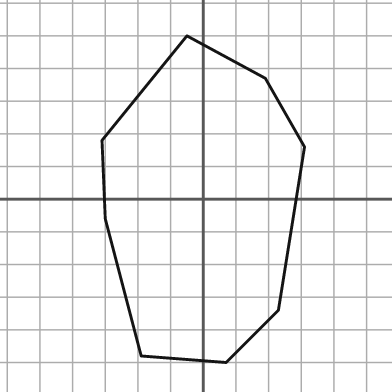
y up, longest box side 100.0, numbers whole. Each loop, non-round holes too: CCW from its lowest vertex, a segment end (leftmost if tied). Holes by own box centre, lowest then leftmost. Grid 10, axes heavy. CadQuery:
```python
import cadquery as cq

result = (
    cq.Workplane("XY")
    .moveTo(7.0, -50.0)
    .lineTo(23.0, -34.0)
    .lineTo(31.0, 16.0)
    .lineTo(19.0, 37.0)
    .lineTo(-5.0, 50.0)
    .lineTo(-31.0, 18.0)
    .lineTo(-30.0, -6.0)
    .lineTo(-19.0, -48.0)
    .close()
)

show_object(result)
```